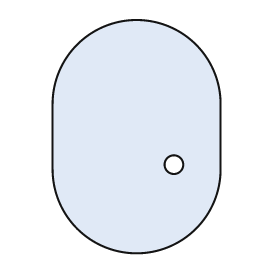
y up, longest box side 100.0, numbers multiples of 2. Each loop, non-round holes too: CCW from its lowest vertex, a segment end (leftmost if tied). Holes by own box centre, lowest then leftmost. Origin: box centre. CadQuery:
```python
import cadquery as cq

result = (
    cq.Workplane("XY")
    .moveTo(-36.0, -14.0)
    .threePointArc((0.0, -50.0), (36.0, -14.0))
    .lineTo(36.0, 14.0)
    .threePointArc((0.0, 50.0), (-36.0, 14.0))
    .close()
    .moveTo(16.0, -12.0)
    .circle(4.0)
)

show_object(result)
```